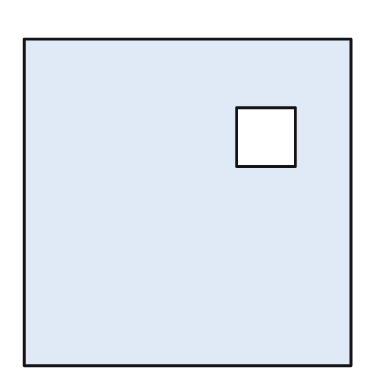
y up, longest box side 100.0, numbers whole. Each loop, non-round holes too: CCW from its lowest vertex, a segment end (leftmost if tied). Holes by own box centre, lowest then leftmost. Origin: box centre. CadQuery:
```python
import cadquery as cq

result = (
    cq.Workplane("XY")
    .moveTo(-50.0, -50.0)
    .lineTo(50.0, -50.0)
    .lineTo(50.0, 50.0)
    .lineTo(-50.0, 50.0)
    .close()
    .moveTo(15.0, 11.0)
    .lineTo(33.0, 11.0)
    .lineTo(33.0, 29.0)
    .lineTo(15.0, 29.0)
    .close()
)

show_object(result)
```